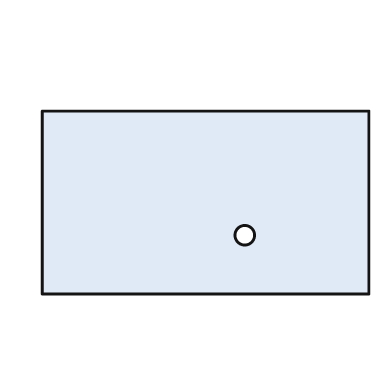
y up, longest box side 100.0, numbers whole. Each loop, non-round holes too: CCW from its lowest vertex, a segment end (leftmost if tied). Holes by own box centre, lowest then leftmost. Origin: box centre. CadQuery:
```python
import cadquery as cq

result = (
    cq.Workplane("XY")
    .moveTo(-50.0, -28.0)
    .lineTo(50.0, -28.0)
    .lineTo(50.0, 28.0)
    .lineTo(-50.0, 28.0)
    .close()
    .moveTo(12.0, -10.0)
    .circle(3.0)
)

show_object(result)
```